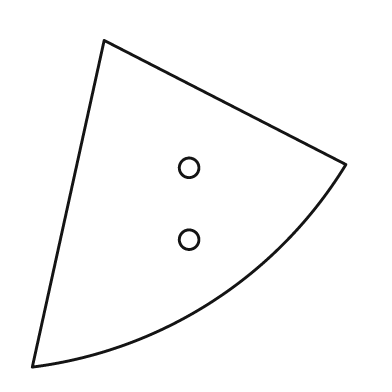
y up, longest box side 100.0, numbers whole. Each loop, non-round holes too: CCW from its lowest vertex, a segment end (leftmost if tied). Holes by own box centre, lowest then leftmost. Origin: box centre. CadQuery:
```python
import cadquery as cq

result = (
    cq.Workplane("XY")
    .moveTo(-48.0, -50.0)
    .threePointArc((7.0, -30.0), (48.0, 12.0))
    .lineTo(-26.0, 50.0)
    .close()
    .moveTo(0.0, -11.0)
    .circle(3.0)
    .moveTo(0.0, 11.0)
    .circle(3.0)
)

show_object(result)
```